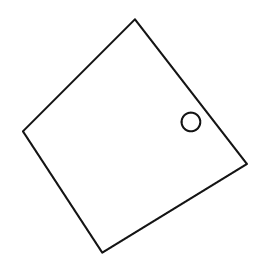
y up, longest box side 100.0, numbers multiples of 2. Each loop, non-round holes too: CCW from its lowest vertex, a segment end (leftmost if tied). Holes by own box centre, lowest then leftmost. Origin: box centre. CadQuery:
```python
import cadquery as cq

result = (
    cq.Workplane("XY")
    .moveTo(-14.0, -50.0)
    .lineTo(48.0, -12.0)
    .lineTo(0.0, 50.0)
    .lineTo(-48.0, 2.0)
    .close()
    .moveTo(24.0, 6.0)
    .circle(4.0)
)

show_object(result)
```